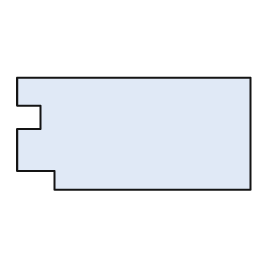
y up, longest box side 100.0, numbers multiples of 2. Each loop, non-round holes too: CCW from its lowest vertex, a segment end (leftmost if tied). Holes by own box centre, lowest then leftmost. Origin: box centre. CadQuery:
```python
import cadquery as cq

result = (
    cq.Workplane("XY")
    .moveTo(-34.0, -24.0)
    .lineTo(50.0, -24.0)
    .lineTo(50.0, 24.0)
    .lineTo(-50.0, 24.0)
    .lineTo(-50.0, 12.0)
    .lineTo(-40.0, 12.0)
    .lineTo(-40.0, 2.0)
    .lineTo(-50.0, 2.0)
    .lineTo(-50.0, -16.0)
    .lineTo(-34.0, -16.0)
    .close()
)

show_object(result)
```